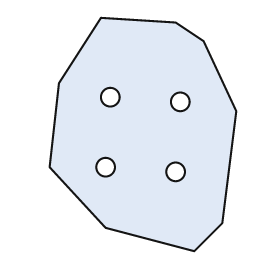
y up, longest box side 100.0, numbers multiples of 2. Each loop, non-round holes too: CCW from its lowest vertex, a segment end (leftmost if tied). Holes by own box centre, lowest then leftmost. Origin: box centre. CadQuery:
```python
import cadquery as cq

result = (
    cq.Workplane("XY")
    .moveTo(22.0, -50.0)
    .lineTo(34.0, -38.0)
    .lineTo(40.0, 10.0)
    .lineTo(26.0, 40.0)
    .lineTo(14.0, 48.0)
    .lineTo(-18.0, 50.0)
    .lineTo(-36.0, 22.0)
    .lineTo(-40.0, -14.0)
    .lineTo(-16.0, -40.0)
    .close()
    .moveTo(14.0, -16.0)
    .circle(4.0)
    .moveTo(-16.0, -14.0)
    .circle(4.0)
    .moveTo(16.0, 14.0)
    .circle(4.0)
    .moveTo(-14.0, 16.0)
    .circle(4.0)
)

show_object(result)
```